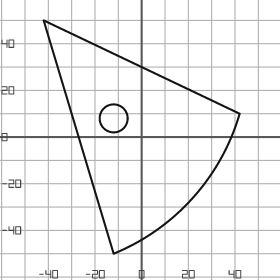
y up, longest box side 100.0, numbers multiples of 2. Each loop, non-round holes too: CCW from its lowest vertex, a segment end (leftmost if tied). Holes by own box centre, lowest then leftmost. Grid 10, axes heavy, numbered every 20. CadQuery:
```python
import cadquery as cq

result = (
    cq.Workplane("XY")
    .moveTo(-12.0, -50.0)
    .threePointArc((22.0, -26.0), (42.0, 10.0))
    .lineTo(-42.0, 50.0)
    .close()
    .moveTo(-12.0, 8.0)
    .circle(6.0)
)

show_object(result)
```